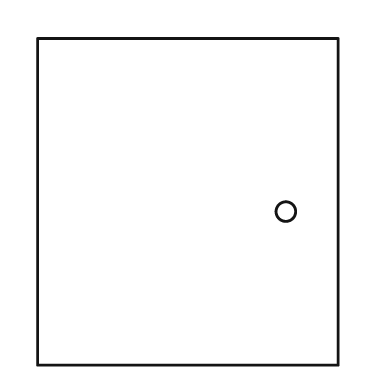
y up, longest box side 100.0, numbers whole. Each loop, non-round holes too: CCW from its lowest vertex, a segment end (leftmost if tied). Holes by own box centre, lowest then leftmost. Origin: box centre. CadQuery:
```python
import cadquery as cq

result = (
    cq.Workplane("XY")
    .moveTo(-46.0, -50.0)
    .lineTo(46.0, -50.0)
    .lineTo(46.0, 50.0)
    .lineTo(-46.0, 50.0)
    .close()
    .moveTo(30.0, -3.0)
    .circle(3.0)
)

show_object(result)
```